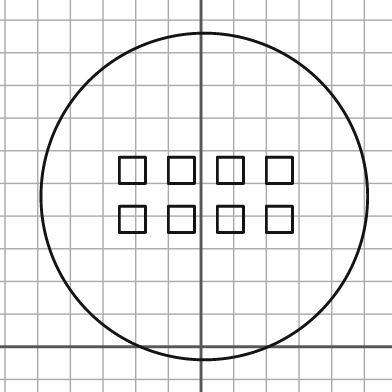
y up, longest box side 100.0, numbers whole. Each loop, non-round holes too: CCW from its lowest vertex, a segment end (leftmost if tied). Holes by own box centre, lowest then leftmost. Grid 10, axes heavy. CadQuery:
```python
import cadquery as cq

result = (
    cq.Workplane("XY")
    .moveTo(1.0, 46.0)
    .circle(50.0)
    .moveTo(-25.0, 35.0)
    .lineTo(-17.0, 35.0)
    .lineTo(-17.0, 43.0)
    .lineTo(-25.0, 43.0)
    .close()
    .moveTo(-10.0, 35.0)
    .lineTo(-2.0, 35.0)
    .lineTo(-2.0, 43.0)
    .lineTo(-10.0, 43.0)
    .close()
    .moveTo(5.0, 35.0)
    .lineTo(13.0, 35.0)
    .lineTo(13.0, 43.0)
    .lineTo(5.0, 43.0)
    .close()
    .moveTo(20.0, 35.0)
    .lineTo(28.0, 35.0)
    .lineTo(28.0, 43.0)
    .lineTo(20.0, 43.0)
    .close()
    .moveTo(-25.0, 50.0)
    .lineTo(-17.0, 50.0)
    .lineTo(-17.0, 58.0)
    .lineTo(-25.0, 58.0)
    .close()
    .moveTo(-10.0, 50.0)
    .lineTo(-2.0, 50.0)
    .lineTo(-2.0, 58.0)
    .lineTo(-10.0, 58.0)
    .close()
    .moveTo(5.0, 50.0)
    .lineTo(13.0, 50.0)
    .lineTo(13.0, 58.0)
    .lineTo(5.0, 58.0)
    .close()
    .moveTo(20.0, 50.0)
    .lineTo(28.0, 50.0)
    .lineTo(28.0, 58.0)
    .lineTo(20.0, 58.0)
    .close()
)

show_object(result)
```